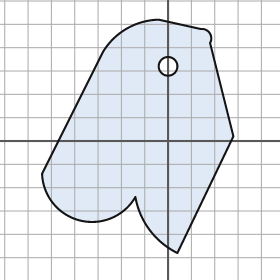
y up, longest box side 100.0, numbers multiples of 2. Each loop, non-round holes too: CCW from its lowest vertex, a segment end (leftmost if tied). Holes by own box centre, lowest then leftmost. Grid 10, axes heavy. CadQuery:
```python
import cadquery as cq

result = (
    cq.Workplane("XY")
    .moveTo(4.0, -48.0)
    .lineTo(28.0, 2.0)
    .lineTo(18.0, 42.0)
    .threePointArc((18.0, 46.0), (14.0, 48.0))
    .lineTo(-4.0, 52.0)
    .threePointArc((-18.0, 48.0), (-28.0, 38.0))
    .lineTo(-54.0, -14.0)
    .threePointArc((-38.0, -34.0), (-14.0, -24.0))
    .threePointArc((-8.0, -38.0), (4.0, -48.0))
    .close()
    .moveTo(0.0, 32.0)
    .circle(4.0)
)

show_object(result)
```